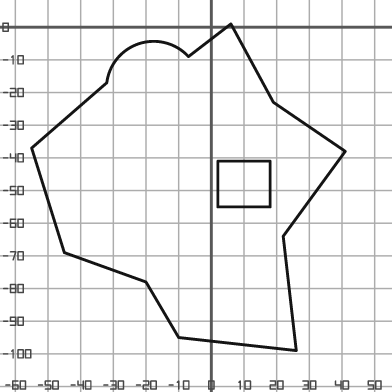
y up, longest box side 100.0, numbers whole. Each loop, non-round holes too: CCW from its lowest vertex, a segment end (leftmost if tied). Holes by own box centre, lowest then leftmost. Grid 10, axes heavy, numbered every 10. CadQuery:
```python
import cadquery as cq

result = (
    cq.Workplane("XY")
    .moveTo(26.0, -99.0)
    .lineTo(22.0, -64.0)
    .lineTo(41.0, -38.0)
    .lineTo(19.0, -23.0)
    .lineTo(6.0, 1.0)
    .lineTo(-7.0, -9.0)
    .threePointArc((-22.0, -5.0), (-32.0, -17.0))
    .lineTo(-55.0, -37.0)
    .lineTo(-45.0, -69.0)
    .lineTo(-20.0, -78.0)
    .lineTo(-10.0, -95.0)
    .close()
    .moveTo(2.0, -55.0)
    .lineTo(18.0, -55.0)
    .lineTo(18.0, -41.0)
    .lineTo(2.0, -41.0)
    .close()
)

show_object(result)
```